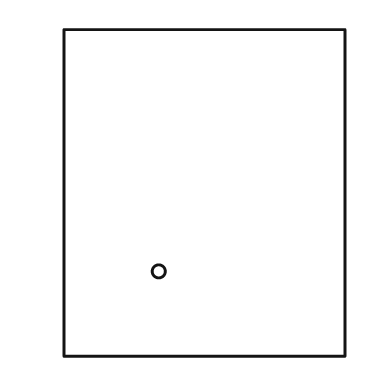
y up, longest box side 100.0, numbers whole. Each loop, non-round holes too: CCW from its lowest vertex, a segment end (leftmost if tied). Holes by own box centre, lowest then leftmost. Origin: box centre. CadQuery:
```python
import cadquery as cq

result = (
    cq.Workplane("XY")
    .moveTo(-43.0, -50.0)
    .lineTo(43.0, -50.0)
    .lineTo(43.0, 50.0)
    .lineTo(-43.0, 50.0)
    .close()
    .moveTo(-14.0, -24.0)
    .circle(2.0)
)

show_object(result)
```